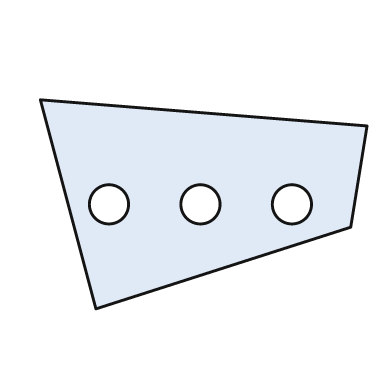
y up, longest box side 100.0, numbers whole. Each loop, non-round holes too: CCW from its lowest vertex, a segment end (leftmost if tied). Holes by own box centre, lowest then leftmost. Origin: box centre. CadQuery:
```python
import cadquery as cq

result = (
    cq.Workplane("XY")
    .moveTo(-33.0, -32.0)
    .lineTo(45.0, -7.0)
    .lineTo(50.0, 24.0)
    .lineTo(-50.0, 32.0)
    .close()
    .moveTo(-29.0, 0.0)
    .circle(6.0)
    .moveTo(-1.0, 0.0)
    .circle(6.0)
    .moveTo(27.0, 0.0)
    .circle(6.0)
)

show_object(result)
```